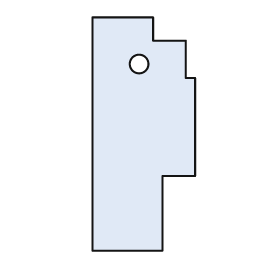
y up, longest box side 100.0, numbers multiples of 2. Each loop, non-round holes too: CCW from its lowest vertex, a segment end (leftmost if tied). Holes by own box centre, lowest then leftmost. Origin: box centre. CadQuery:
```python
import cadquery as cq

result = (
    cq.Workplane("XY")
    .moveTo(-22.0, -50.0)
    .lineTo(8.0, -50.0)
    .lineTo(8.0, -18.0)
    .lineTo(22.0, -18.0)
    .lineTo(22.0, 24.0)
    .lineTo(18.0, 24.0)
    .lineTo(18.0, 40.0)
    .lineTo(4.0, 40.0)
    .lineTo(4.0, 50.0)
    .lineTo(-22.0, 50.0)
    .close()
    .moveTo(-2.0, 30.0)
    .circle(4.0)
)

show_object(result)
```